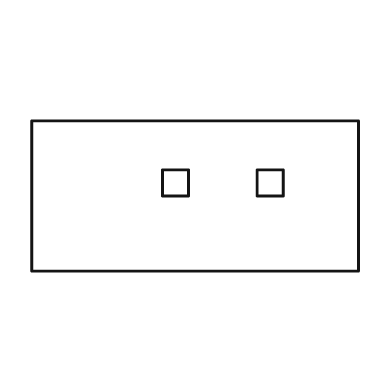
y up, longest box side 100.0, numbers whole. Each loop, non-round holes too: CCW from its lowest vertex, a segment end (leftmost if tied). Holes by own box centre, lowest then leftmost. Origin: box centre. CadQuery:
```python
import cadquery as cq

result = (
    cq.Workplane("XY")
    .moveTo(-50.0, -23.0)
    .lineTo(50.0, -23.0)
    .lineTo(50.0, 23.0)
    .lineTo(-50.0, 23.0)
    .close()
    .moveTo(-10.0, 0.0)
    .lineTo(-2.0, 0.0)
    .lineTo(-2.0, 8.0)
    .lineTo(-10.0, 8.0)
    .close()
    .moveTo(19.0, 0.0)
    .lineTo(27.0, 0.0)
    .lineTo(27.0, 8.0)
    .lineTo(19.0, 8.0)
    .close()
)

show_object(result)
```